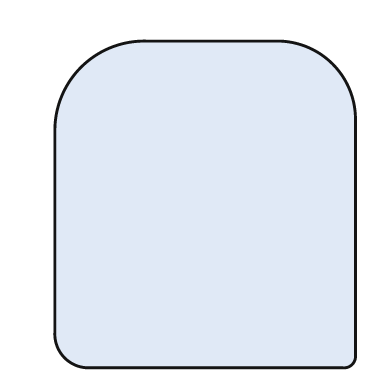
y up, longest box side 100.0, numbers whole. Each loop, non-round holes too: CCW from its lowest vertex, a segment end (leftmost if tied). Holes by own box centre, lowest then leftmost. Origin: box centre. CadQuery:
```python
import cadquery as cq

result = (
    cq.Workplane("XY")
    .moveTo(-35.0, -50.0)
    .lineTo(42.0, -50.0)
    .threePointArc((45.0, -49.0), (46.0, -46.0))
    .lineTo(46.0, 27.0)
    .threePointArc((39.0, 43.0), (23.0, 50.0))
    .lineTo(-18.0, 50.0)
    .threePointArc((-38.0, 42.0), (-46.0, 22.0))
    .lineTo(-46.0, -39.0)
    .threePointArc((-43.0, -47.0), (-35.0, -50.0))
    .close()
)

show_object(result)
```